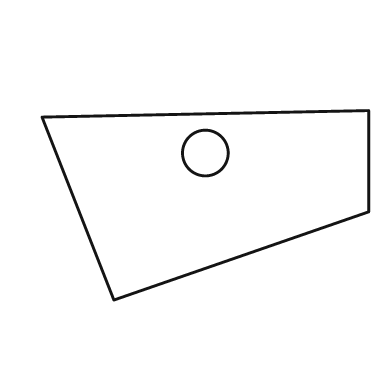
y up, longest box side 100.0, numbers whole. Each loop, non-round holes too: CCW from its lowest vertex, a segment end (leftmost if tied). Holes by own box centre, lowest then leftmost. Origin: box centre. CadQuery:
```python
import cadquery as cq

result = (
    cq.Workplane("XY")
    .moveTo(-28.0, -29.0)
    .lineTo(50.0, -2.0)
    .lineTo(50.0, 29.0)
    .lineTo(-50.0, 27.0)
    .close()
    .moveTo(0.0, 16.0)
    .circle(7.0)
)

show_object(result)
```